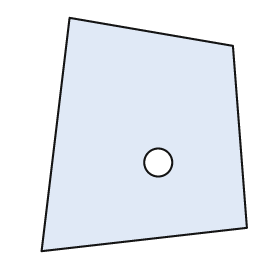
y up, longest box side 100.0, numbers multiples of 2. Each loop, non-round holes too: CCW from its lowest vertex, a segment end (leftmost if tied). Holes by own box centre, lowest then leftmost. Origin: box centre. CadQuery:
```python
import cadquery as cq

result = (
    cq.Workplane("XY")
    .moveTo(-44.0, -50.0)
    .lineTo(44.0, -40.0)
    .lineTo(38.0, 38.0)
    .lineTo(-32.0, 50.0)
    .close()
    .moveTo(6.0, -12.0)
    .circle(6.0)
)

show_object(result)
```